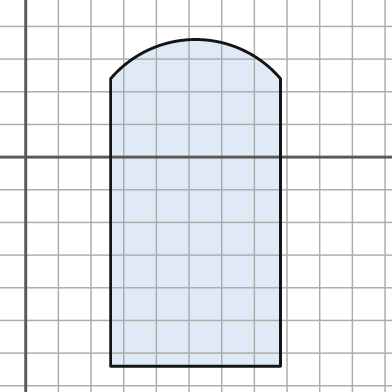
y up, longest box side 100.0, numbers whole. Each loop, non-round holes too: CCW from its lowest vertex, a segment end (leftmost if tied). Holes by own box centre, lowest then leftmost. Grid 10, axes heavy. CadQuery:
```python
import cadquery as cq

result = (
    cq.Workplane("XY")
    .moveTo(26.0, -64.0)
    .lineTo(78.0, -64.0)
    .lineTo(78.0, 24.0)
    .threePointArc((52.0, 36.0), (26.0, 24.0))
    .close()
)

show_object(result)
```